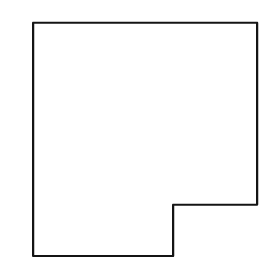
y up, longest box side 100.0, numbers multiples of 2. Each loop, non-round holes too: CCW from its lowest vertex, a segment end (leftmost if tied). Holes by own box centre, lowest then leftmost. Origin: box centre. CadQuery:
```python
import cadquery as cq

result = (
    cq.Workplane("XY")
    .moveTo(-48.0, -50.0)
    .lineTo(12.0, -50.0)
    .lineTo(12.0, -28.0)
    .lineTo(48.0, -28.0)
    .lineTo(48.0, 50.0)
    .lineTo(-48.0, 50.0)
    .close()
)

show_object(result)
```